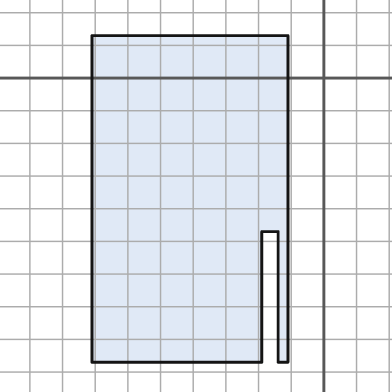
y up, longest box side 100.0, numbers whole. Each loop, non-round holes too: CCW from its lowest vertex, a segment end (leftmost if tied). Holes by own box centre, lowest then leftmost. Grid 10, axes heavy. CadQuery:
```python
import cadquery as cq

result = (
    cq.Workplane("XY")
    .moveTo(-71.0, -87.0)
    .lineTo(-19.0, -87.0)
    .lineTo(-19.0, -47.0)
    .lineTo(-14.0, -47.0)
    .lineTo(-14.0, -87.0)
    .lineTo(-11.0, -87.0)
    .lineTo(-11.0, 13.0)
    .lineTo(-71.0, 13.0)
    .close()
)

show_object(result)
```